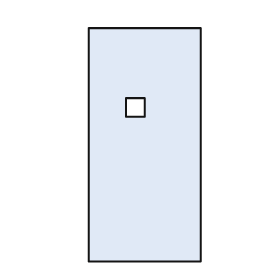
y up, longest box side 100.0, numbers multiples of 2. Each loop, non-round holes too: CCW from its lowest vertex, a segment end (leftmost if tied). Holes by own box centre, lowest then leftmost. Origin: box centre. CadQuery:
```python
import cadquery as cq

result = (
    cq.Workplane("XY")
    .moveTo(-24.0, -50.0)
    .lineTo(24.0, -50.0)
    .lineTo(24.0, 50.0)
    .lineTo(-24.0, 50.0)
    .close()
    .moveTo(-8.0, 12.0)
    .lineTo(0.0, 12.0)
    .lineTo(0.0, 20.0)
    .lineTo(-8.0, 20.0)
    .close()
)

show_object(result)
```